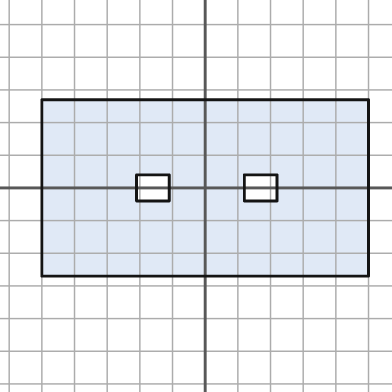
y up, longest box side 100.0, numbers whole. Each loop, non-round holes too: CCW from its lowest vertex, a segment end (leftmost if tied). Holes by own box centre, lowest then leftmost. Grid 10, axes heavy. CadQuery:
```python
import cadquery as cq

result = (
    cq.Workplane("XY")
    .moveTo(-50.0, -27.0)
    .lineTo(50.0, -27.0)
    .lineTo(50.0, 27.0)
    .lineTo(-50.0, 27.0)
    .close()
    .moveTo(-21.0, -4.0)
    .lineTo(-11.0, -4.0)
    .lineTo(-11.0, 4.0)
    .lineTo(-21.0, 4.0)
    .close()
    .moveTo(12.0, -4.0)
    .lineTo(22.0, -4.0)
    .lineTo(22.0, 4.0)
    .lineTo(12.0, 4.0)
    .close()
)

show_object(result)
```